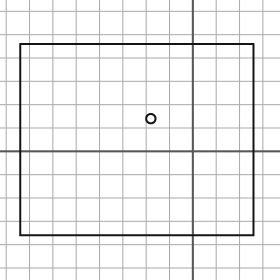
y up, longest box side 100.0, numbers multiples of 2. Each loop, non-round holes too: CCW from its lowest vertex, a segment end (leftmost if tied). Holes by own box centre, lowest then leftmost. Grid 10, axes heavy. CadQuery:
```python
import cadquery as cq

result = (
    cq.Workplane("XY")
    .moveTo(-74.0, -36.0)
    .lineTo(26.0, -36.0)
    .lineTo(26.0, 46.0)
    .lineTo(-74.0, 46.0)
    .close()
    .moveTo(-18.0, 14.0)
    .circle(2.0)
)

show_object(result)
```